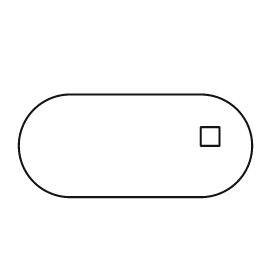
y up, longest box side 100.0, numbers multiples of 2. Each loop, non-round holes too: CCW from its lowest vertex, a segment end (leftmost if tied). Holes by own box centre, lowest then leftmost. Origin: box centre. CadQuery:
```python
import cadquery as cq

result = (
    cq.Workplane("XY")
    .moveTo(-28.0, -22.0)
    .lineTo(28.0, -22.0)
    .threePointArc((50.0, 0.0), (28.0, 22.0))
    .lineTo(-28.0, 22.0)
    .threePointArc((-50.0, 0.0), (-28.0, -22.0))
    .close()
    .moveTo(28.0, 0.0)
    .lineTo(36.0, 0.0)
    .lineTo(36.0, 8.0)
    .lineTo(28.0, 8.0)
    .close()
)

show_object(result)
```